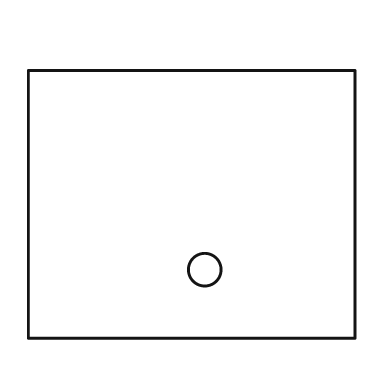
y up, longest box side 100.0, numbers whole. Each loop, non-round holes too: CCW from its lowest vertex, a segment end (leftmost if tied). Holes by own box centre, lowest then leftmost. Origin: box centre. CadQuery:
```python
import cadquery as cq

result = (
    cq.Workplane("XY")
    .moveTo(-50.0, -41.0)
    .lineTo(50.0, -41.0)
    .lineTo(50.0, 41.0)
    .lineTo(-50.0, 41.0)
    .close()
    .moveTo(4.0, -20.0)
    .circle(5.0)
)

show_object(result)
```